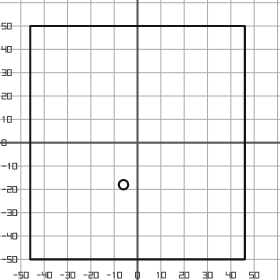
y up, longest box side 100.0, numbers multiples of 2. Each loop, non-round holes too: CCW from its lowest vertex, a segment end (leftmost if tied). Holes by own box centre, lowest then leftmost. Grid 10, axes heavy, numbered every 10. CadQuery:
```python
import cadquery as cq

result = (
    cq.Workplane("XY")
    .moveTo(-46.0, -50.0)
    .lineTo(46.0, -50.0)
    .lineTo(46.0, 50.0)
    .lineTo(-46.0, 50.0)
    .close()
    .moveTo(-6.0, -18.0)
    .circle(2.0)
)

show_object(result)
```